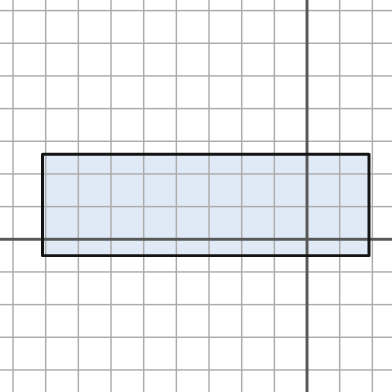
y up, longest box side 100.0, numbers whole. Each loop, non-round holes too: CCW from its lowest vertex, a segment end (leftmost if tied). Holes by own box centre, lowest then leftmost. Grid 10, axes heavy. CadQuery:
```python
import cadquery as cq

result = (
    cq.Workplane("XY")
    .moveTo(-81.0, -5.0)
    .lineTo(19.0, -5.0)
    .lineTo(19.0, 26.0)
    .lineTo(-81.0, 26.0)
    .close()
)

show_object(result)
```